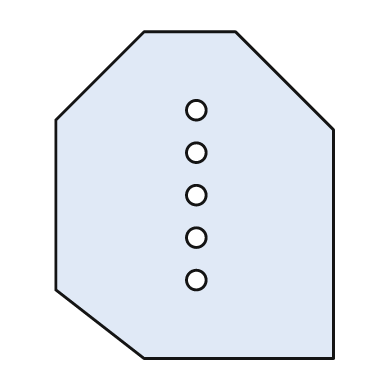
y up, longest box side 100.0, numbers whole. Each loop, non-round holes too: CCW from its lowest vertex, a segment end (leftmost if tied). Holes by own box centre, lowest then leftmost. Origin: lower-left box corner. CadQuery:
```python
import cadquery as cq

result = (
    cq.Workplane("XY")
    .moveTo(27.0, 0.0)
    .lineTo(85.0, 0.0)
    .lineTo(85.0, 70.0)
    .lineTo(55.0, 100.0)
    .lineTo(27.0, 100.0)
    .lineTo(0.0, 73.0)
    .lineTo(0.0, 21.0)
    .close()
    .moveTo(43.0, 24.0)
    .circle(3.0)
    .moveTo(43.0, 37.0)
    .circle(3.0)
    .moveTo(43.0, 50.0)
    .circle(3.0)
    .moveTo(43.0, 63.0)
    .circle(3.0)
    .moveTo(43.0, 76.0)
    .circle(3.0)
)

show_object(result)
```